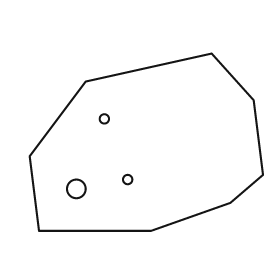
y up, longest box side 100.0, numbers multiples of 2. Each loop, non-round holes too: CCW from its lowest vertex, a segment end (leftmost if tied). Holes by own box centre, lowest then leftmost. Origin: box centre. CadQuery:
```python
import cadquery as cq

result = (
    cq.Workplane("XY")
    .moveTo(-46.0, -38.0)
    .lineTo(2.0, -38.0)
    .lineTo(36.0, -26.0)
    .lineTo(50.0, -14.0)
    .lineTo(46.0, 18.0)
    .lineTo(28.0, 38.0)
    .lineTo(-26.0, 26.0)
    .lineTo(-50.0, -6.0)
    .close()
    .moveTo(-30.0, -20.0)
    .circle(4.0)
    .moveTo(-8.0, -16.0)
    .circle(2.0)
    .moveTo(-18.0, 10.0)
    .circle(2.0)
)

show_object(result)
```